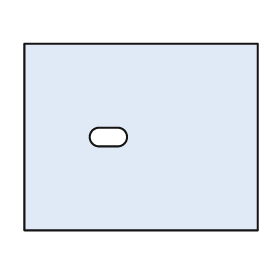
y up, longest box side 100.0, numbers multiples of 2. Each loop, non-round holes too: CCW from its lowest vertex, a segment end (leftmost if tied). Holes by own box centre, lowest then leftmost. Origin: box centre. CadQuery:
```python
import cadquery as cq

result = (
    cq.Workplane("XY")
    .moveTo(-50.0, -40.0)
    .lineTo(50.0, -40.0)
    .lineTo(50.0, 40.0)
    .lineTo(-50.0, 40.0)
    .close()
    .moveTo(-18.0, -4.0)
    .lineTo(-10.0, -4.0)
    .threePointArc((-6.0, 0.0), (-10.0, 4.0))
    .lineTo(-18.0, 4.0)
    .threePointArc((-22.0, 0.0), (-18.0, -4.0))
    .close()
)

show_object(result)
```